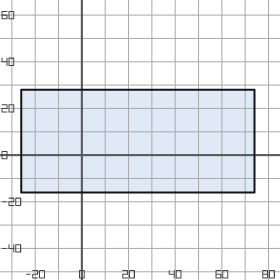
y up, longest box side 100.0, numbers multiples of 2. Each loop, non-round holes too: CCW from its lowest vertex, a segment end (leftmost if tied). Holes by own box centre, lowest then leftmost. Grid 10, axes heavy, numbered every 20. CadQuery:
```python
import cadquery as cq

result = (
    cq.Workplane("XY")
    .moveTo(-26.0, -16.0)
    .lineTo(74.0, -16.0)
    .lineTo(74.0, 28.0)
    .lineTo(-26.0, 28.0)
    .close()
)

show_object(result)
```